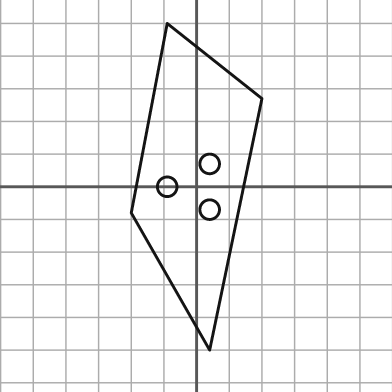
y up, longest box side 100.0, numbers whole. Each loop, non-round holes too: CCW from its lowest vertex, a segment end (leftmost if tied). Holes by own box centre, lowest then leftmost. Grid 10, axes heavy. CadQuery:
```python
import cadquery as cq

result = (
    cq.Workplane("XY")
    .moveTo(4.0, -50.0)
    .lineTo(20.0, 27.0)
    .lineTo(-9.0, 50.0)
    .lineTo(-20.0, -8.0)
    .close()
    .moveTo(4.0, -7.0)
    .circle(3.0)
    .moveTo(-9.0, 0.0)
    .circle(3.0)
    .moveTo(4.0, 7.0)
    .circle(3.0)
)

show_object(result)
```